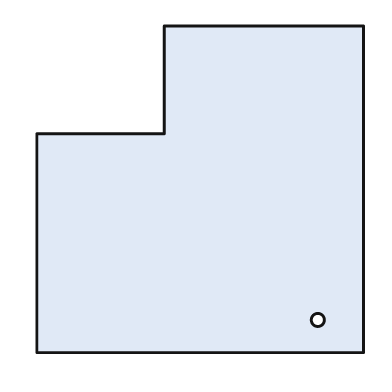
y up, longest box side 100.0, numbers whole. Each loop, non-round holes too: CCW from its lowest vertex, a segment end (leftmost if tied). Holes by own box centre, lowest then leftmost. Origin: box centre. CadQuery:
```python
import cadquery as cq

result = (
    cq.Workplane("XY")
    .moveTo(-50.0, -50.0)
    .lineTo(50.0, -50.0)
    .lineTo(50.0, 50.0)
    .lineTo(-11.0, 50.0)
    .lineTo(-11.0, 17.0)
    .lineTo(-50.0, 17.0)
    .close()
    .moveTo(36.0, -40.0)
    .circle(2.0)
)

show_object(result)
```